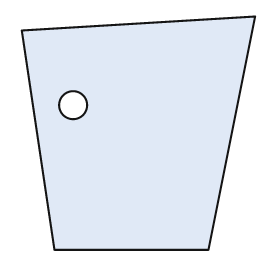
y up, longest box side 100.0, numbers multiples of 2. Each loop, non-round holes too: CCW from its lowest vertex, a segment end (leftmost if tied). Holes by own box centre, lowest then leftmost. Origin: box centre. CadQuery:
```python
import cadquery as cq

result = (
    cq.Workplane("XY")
    .moveTo(-36.0, -50.0)
    .lineTo(30.0, -50.0)
    .lineTo(50.0, 50.0)
    .lineTo(-50.0, 44.0)
    .close()
    .moveTo(-28.0, 12.0)
    .circle(6.0)
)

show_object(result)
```